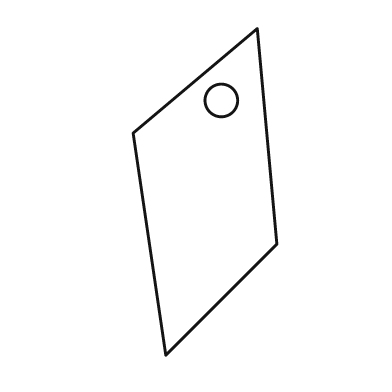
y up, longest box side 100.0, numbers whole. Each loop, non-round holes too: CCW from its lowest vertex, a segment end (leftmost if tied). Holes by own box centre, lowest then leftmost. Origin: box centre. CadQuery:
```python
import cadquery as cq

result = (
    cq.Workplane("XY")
    .moveTo(-12.0, -50.0)
    .lineTo(22.0, -16.0)
    .lineTo(16.0, 50.0)
    .lineTo(-22.0, 18.0)
    .close()
    .moveTo(5.0, 28.0)
    .circle(5.0)
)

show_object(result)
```